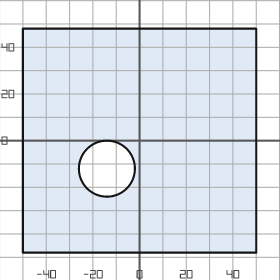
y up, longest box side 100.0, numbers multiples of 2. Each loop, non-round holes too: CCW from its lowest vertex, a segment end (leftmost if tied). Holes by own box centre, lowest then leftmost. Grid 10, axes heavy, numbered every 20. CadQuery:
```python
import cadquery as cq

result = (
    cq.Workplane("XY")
    .moveTo(-50.0, -48.0)
    .lineTo(50.0, -48.0)
    .lineTo(50.0, 48.0)
    .lineTo(-50.0, 48.0)
    .close()
    .moveTo(-14.0, -12.0)
    .circle(12.0)
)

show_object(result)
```